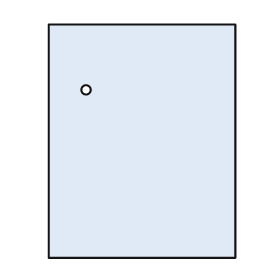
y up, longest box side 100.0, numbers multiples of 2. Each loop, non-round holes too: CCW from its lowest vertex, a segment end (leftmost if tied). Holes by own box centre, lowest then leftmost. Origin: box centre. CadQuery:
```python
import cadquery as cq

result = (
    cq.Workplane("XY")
    .moveTo(-40.0, -50.0)
    .lineTo(40.0, -50.0)
    .lineTo(40.0, 50.0)
    .lineTo(-40.0, 50.0)
    .close()
    .moveTo(-24.0, 22.0)
    .circle(2.0)
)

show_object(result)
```